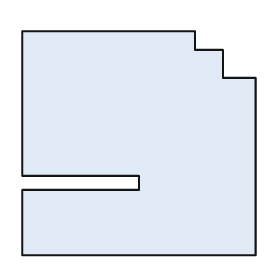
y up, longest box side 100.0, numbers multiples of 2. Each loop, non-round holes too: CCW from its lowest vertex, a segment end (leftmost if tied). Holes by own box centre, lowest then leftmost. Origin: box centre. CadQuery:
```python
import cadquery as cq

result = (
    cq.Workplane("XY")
    .moveTo(-50.0, -48.0)
    .lineTo(50.0, -48.0)
    .lineTo(50.0, 28.0)
    .lineTo(36.0, 28.0)
    .lineTo(36.0, 40.0)
    .lineTo(24.0, 40.0)
    .lineTo(24.0, 48.0)
    .lineTo(-50.0, 48.0)
    .lineTo(-50.0, -14.0)
    .lineTo(0.0, -14.0)
    .lineTo(0.0, -20.0)
    .lineTo(-50.0, -20.0)
    .close()
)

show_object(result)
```